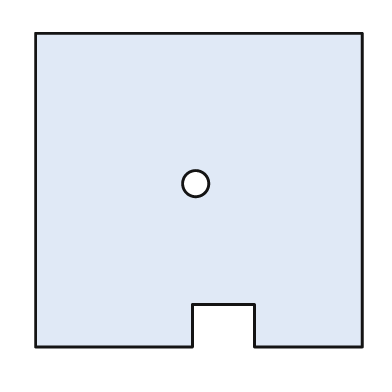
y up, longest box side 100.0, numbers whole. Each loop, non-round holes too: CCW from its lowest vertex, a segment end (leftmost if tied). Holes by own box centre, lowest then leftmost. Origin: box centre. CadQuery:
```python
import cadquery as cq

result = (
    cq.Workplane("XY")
    .moveTo(-50.0, -48.0)
    .lineTo(-2.0, -48.0)
    .lineTo(-2.0, -35.0)
    .lineTo(17.0, -35.0)
    .lineTo(17.0, -48.0)
    .lineTo(50.0, -48.0)
    .lineTo(50.0, 48.0)
    .lineTo(-50.0, 48.0)
    .close()
    .moveTo(-1.0, 2.0)
    .circle(4.0)
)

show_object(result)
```